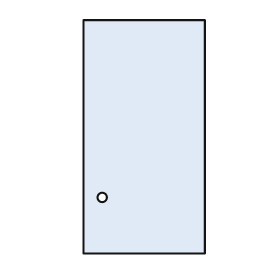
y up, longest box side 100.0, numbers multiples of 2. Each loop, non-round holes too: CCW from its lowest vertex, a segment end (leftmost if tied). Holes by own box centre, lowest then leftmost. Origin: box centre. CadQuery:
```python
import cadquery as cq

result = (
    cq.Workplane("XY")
    .moveTo(-26.0, -50.0)
    .lineTo(26.0, -50.0)
    .lineTo(26.0, 50.0)
    .lineTo(-26.0, 50.0)
    .close()
    .moveTo(-18.0, -26.0)
    .circle(2.0)
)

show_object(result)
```